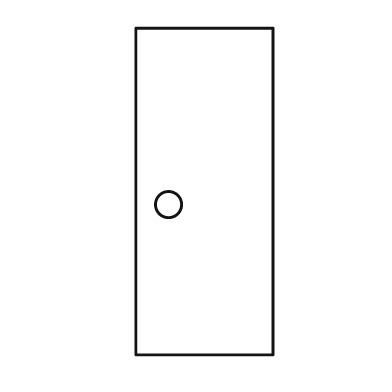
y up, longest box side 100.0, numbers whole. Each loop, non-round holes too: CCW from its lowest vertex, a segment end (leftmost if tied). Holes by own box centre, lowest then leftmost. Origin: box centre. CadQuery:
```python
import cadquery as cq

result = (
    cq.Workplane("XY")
    .moveTo(-21.0, -50.0)
    .lineTo(21.0, -50.0)
    .lineTo(21.0, 50.0)
    .lineTo(-21.0, 50.0)
    .close()
    .moveTo(-11.0, -4.0)
    .circle(4.0)
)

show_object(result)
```